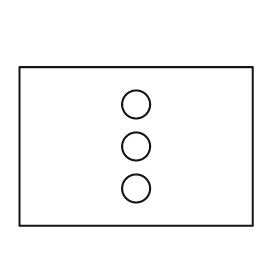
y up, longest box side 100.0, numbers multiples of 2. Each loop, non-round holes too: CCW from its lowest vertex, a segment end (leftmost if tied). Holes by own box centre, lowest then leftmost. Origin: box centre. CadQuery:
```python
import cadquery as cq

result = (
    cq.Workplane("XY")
    .moveTo(-50.0, -34.0)
    .lineTo(50.0, -34.0)
    .lineTo(50.0, 34.0)
    .lineTo(-50.0, 34.0)
    .close()
    .moveTo(0.0, -18.0)
    .circle(6.0)
    .moveTo(0.0, 0.0)
    .circle(6.0)
    .moveTo(0.0, 18.0)
    .circle(6.0)
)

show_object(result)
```